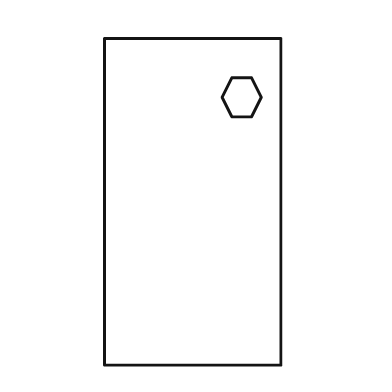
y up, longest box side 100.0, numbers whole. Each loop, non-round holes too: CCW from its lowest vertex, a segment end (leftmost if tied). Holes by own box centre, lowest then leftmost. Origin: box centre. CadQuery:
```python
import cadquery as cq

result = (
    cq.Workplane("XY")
    .moveTo(-27.0, -50.0)
    .lineTo(27.0, -50.0)
    .lineTo(27.0, 50.0)
    .lineTo(-27.0, 50.0)
    .close()
    .moveTo(12.0, 26.0)
    .lineTo(18.0, 26.0)
    .lineTo(21.0, 32.0)
    .lineTo(18.0, 38.0)
    .lineTo(12.0, 38.0)
    .lineTo(9.0, 32.0)
    .close()
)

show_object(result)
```